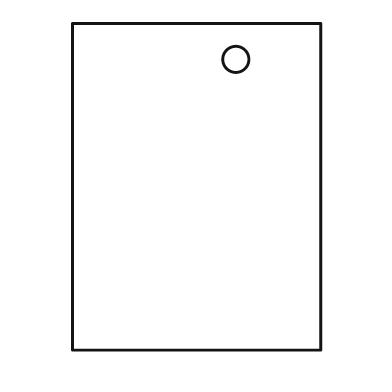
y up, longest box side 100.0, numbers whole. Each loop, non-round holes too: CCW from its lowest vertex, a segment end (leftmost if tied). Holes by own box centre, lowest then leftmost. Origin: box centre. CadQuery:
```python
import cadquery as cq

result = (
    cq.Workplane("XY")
    .moveTo(-38.0, -50.0)
    .lineTo(38.0, -50.0)
    .lineTo(38.0, 50.0)
    .lineTo(-38.0, 50.0)
    .close()
    .moveTo(12.0, 39.0)
    .circle(4.0)
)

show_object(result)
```